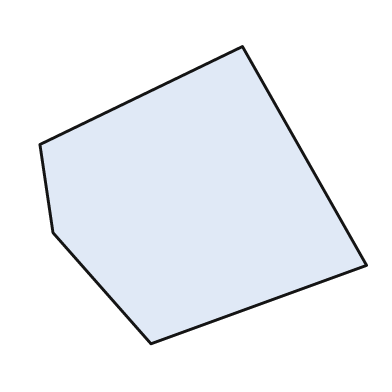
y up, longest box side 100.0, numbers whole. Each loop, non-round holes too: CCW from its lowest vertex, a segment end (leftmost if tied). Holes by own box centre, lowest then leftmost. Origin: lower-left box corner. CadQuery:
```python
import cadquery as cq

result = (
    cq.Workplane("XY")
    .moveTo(34.0, 0.0)
    .lineTo(100.0, 24.0)
    .lineTo(62.0, 91.0)
    .lineTo(0.0, 61.0)
    .lineTo(4.0, 34.0)
    .close()
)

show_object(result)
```